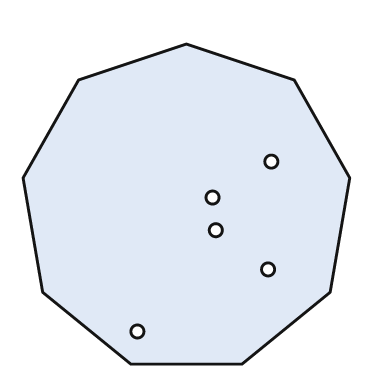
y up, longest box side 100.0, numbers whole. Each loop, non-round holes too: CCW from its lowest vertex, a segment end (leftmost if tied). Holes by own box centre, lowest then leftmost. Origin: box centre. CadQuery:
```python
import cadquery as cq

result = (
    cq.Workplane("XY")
    .moveTo(-17.0, -49.0)
    .lineTo(17.0, -49.0)
    .lineTo(44.0, -27.0)
    .lineTo(50.0, 8.0)
    .lineTo(33.0, 38.0)
    .lineTo(0.0, 49.0)
    .lineTo(-33.0, 38.0)
    .lineTo(-50.0, 8.0)
    .lineTo(-44.0, -27.0)
    .close()
    .moveTo(-15.0, -39.0)
    .circle(2.0)
    .moveTo(25.0, -20.0)
    .circle(2.0)
    .moveTo(9.0, -8.0)
    .circle(2.0)
    .moveTo(8.0, 2.0)
    .circle(2.0)
    .moveTo(26.0, 13.0)
    .circle(2.0)
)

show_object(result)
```